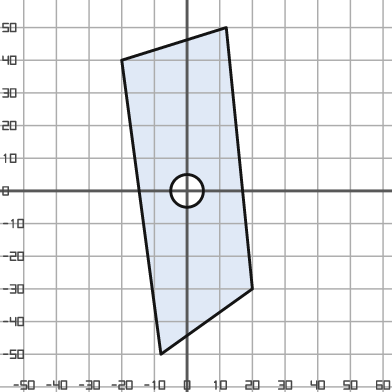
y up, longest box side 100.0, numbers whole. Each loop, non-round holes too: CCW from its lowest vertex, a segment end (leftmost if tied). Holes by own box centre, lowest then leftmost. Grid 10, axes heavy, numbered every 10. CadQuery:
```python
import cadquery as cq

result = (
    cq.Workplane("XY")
    .moveTo(-8.0, -50.0)
    .lineTo(20.0, -30.0)
    .lineTo(12.0, 50.0)
    .lineTo(-20.0, 40.0)
    .close()
    .moveTo(0.0, 0.0)
    .circle(5.0)
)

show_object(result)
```